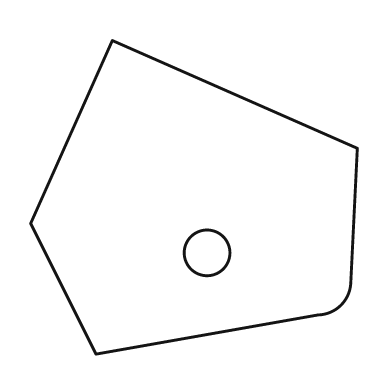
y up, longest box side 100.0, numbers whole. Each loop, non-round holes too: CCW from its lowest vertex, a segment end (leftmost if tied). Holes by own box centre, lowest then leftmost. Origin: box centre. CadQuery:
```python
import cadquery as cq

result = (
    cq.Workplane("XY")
    .moveTo(-30.0, -48.0)
    .lineTo(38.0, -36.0)
    .threePointArc((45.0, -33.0), (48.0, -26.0))
    .lineTo(50.0, 15.0)
    .lineTo(-25.0, 48.0)
    .lineTo(-50.0, -8.0)
    .close()
    .moveTo(4.0, -17.0)
    .circle(7.0)
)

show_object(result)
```